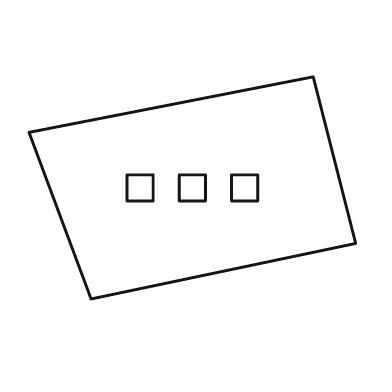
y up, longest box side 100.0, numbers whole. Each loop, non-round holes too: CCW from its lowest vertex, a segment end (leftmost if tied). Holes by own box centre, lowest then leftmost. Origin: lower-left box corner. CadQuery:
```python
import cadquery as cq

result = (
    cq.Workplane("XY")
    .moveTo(19.0, 0.0)
    .lineTo(100.0, 17.0)
    .lineTo(87.0, 68.0)
    .lineTo(0.0, 51.0)
    .close()
    .moveTo(30.0, 30.0)
    .lineTo(38.0, 30.0)
    .lineTo(38.0, 38.0)
    .lineTo(30.0, 38.0)
    .close()
    .moveTo(46.0, 30.0)
    .lineTo(54.0, 30.0)
    .lineTo(54.0, 38.0)
    .lineTo(46.0, 38.0)
    .close()
    .moveTo(62.0, 30.0)
    .lineTo(70.0, 30.0)
    .lineTo(70.0, 38.0)
    .lineTo(62.0, 38.0)
    .close()
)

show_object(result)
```